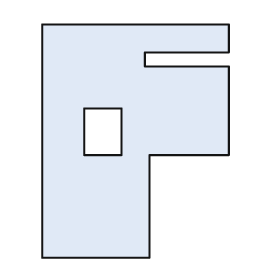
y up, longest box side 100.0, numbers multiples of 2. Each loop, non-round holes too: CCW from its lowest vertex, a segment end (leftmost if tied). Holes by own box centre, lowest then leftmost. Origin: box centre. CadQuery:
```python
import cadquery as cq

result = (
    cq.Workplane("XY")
    .moveTo(-40.0, -50.0)
    .lineTo(6.0, -50.0)
    .lineTo(6.0, -6.0)
    .lineTo(40.0, -6.0)
    .lineTo(40.0, 32.0)
    .lineTo(4.0, 32.0)
    .lineTo(4.0, 38.0)
    .lineTo(40.0, 38.0)
    .lineTo(40.0, 50.0)
    .lineTo(-40.0, 50.0)
    .close()
    .moveTo(-22.0, -6.0)
    .lineTo(-6.0, -6.0)
    .lineTo(-6.0, 14.0)
    .lineTo(-22.0, 14.0)
    .close()
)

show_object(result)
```